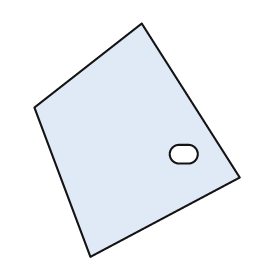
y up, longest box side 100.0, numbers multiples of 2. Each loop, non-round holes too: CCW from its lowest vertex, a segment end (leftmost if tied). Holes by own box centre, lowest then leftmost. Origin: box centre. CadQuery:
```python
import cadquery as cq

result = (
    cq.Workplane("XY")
    .moveTo(-20.0, -50.0)
    .lineTo(44.0, -16.0)
    .lineTo(2.0, 50.0)
    .lineTo(-44.0, 14.0)
    .close()
    .moveTo(18.0, -10.0)
    .lineTo(22.0, -10.0)
    .threePointArc((26.0, -6.0), (22.0, -2.0))
    .lineTo(18.0, -2.0)
    .threePointArc((14.0, -6.0), (18.0, -10.0))
    .close()
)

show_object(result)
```